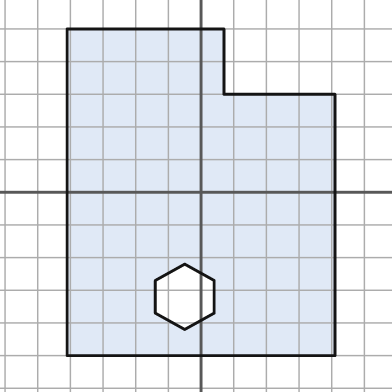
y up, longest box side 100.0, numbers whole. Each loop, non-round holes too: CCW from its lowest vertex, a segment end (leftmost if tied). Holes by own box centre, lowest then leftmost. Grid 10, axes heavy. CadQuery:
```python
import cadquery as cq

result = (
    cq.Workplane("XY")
    .moveTo(-41.0, -50.0)
    .lineTo(41.0, -50.0)
    .lineTo(41.0, 30.0)
    .lineTo(7.0, 30.0)
    .lineTo(7.0, 50.0)
    .lineTo(-41.0, 50.0)
    .close()
    .moveTo(-5.0, -42.0)
    .lineTo(4.0, -37.0)
    .lineTo(4.0, -27.0)
    .lineTo(-5.0, -22.0)
    .lineTo(-14.0, -27.0)
    .lineTo(-14.0, -37.0)
    .close()
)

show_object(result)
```